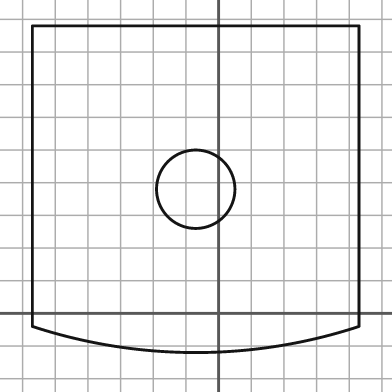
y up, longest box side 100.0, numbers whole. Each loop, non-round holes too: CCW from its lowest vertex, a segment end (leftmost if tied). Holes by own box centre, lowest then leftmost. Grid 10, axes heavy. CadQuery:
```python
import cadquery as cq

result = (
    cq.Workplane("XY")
    .moveTo(-57.0, -4.0)
    .threePointArc((-7.0, -12.0), (43.0, -4.0))
    .lineTo(43.0, 88.0)
    .lineTo(-57.0, 88.0)
    .close()
    .moveTo(-7.0, 38.0)
    .circle(12.0)
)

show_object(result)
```